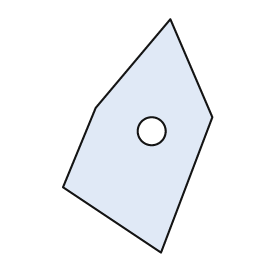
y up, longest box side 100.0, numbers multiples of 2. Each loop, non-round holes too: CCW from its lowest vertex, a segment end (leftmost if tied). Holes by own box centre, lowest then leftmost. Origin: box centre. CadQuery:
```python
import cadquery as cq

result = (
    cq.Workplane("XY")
    .moveTo(10.0, -50.0)
    .lineTo(32.0, 8.0)
    .lineTo(14.0, 50.0)
    .lineTo(-18.0, 12.0)
    .lineTo(-32.0, -22.0)
    .close()
    .moveTo(6.0, 2.0)
    .circle(6.0)
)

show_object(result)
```